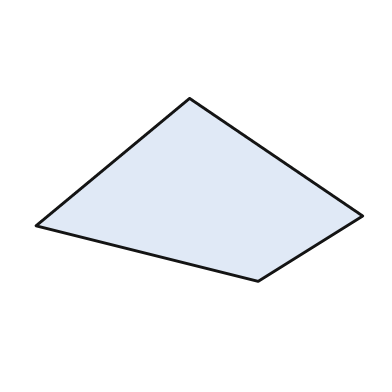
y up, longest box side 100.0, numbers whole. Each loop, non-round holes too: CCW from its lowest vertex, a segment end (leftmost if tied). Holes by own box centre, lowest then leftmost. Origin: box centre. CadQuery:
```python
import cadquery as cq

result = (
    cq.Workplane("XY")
    .moveTo(18.0, -28.0)
    .lineTo(50.0, -8.0)
    .lineTo(-3.0, 28.0)
    .lineTo(-50.0, -11.0)
    .close()
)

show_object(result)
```